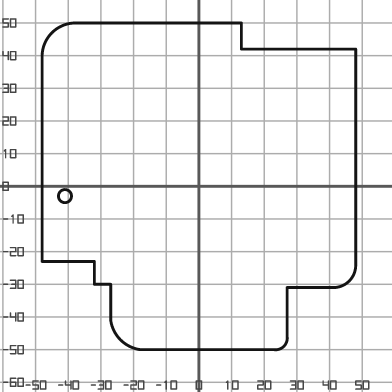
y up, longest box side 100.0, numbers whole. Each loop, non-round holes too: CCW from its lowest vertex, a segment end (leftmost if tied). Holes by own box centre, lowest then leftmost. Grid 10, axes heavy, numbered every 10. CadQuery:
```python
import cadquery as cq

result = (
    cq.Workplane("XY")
    .moveTo(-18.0, -50.0)
    .lineTo(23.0, -50.0)
    .threePointArc((26.0, -49.0), (27.0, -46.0))
    .lineTo(27.0, -31.0)
    .lineTo(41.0, -31.0)
    .threePointArc((46.0, -29.0), (48.0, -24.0))
    .lineTo(48.0, 42.0)
    .lineTo(13.0, 42.0)
    .lineTo(13.0, 50.0)
    .lineTo(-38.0, 50.0)
    .threePointArc((-45.0, 47.0), (-48.0, 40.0))
    .lineTo(-48.0, -23.0)
    .lineTo(-32.0, -23.0)
    .lineTo(-32.0, -30.0)
    .lineTo(-27.0, -30.0)
    .lineTo(-27.0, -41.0)
    .threePointArc((-24.0, -47.0), (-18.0, -50.0))
    .close()
    .moveTo(-41.0, -3.0)
    .circle(2.0)
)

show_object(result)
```